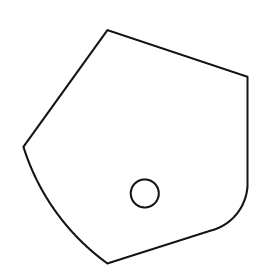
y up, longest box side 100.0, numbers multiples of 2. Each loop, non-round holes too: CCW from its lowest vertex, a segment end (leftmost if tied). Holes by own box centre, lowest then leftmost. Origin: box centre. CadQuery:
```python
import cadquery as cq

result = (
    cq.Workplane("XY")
    .moveTo(-12.0, -50.0)
    .lineTo(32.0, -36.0)
    .threePointArc((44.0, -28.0), (48.0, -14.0))
    .lineTo(48.0, 30.0)
    .lineTo(-12.0, 50.0)
    .lineTo(-48.0, 0.0)
    .threePointArc((-34.0, -28.0), (-12.0, -50.0))
    .close()
    .moveTo(4.0, -20.0)
    .circle(6.0)
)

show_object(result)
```